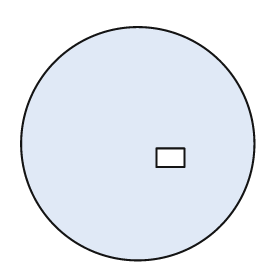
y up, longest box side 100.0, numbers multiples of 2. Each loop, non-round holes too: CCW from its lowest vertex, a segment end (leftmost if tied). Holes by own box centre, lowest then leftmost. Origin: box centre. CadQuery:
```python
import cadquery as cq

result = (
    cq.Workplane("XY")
    .moveTo(0.0, 0.0)
    .circle(50.0)
    .moveTo(8.0, -10.0)
    .lineTo(20.0, -10.0)
    .lineTo(20.0, -2.0)
    .lineTo(8.0, -2.0)
    .close()
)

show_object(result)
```